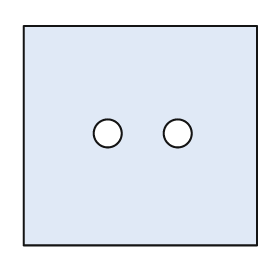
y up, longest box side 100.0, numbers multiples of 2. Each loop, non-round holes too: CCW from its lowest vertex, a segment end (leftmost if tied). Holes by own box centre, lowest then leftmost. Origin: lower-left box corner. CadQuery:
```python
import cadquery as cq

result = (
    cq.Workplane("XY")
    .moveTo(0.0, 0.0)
    .lineTo(100.0, 0.0)
    .lineTo(100.0, 94.0)
    .lineTo(0.0, 94.0)
    .close()
    .moveTo(36.0, 48.0)
    .circle(6.0)
    .moveTo(66.0, 48.0)
    .circle(6.0)
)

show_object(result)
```